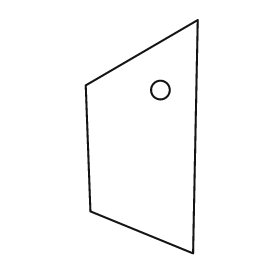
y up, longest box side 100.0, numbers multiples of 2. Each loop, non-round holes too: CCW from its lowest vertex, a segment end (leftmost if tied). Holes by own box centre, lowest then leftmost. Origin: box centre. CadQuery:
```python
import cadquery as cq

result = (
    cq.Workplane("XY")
    .moveTo(22.0, -50.0)
    .lineTo(24.0, 50.0)
    .lineTo(-24.0, 22.0)
    .lineTo(-22.0, -32.0)
    .close()
    .moveTo(8.0, 20.0)
    .circle(4.0)
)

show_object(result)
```